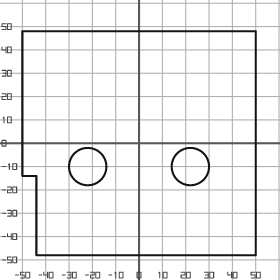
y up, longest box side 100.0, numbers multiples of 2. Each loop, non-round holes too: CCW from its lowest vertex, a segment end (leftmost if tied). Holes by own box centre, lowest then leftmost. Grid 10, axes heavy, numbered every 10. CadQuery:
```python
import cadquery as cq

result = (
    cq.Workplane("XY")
    .moveTo(-44.0, -48.0)
    .lineTo(50.0, -48.0)
    .lineTo(50.0, 48.0)
    .lineTo(-50.0, 48.0)
    .lineTo(-50.0, -14.0)
    .lineTo(-44.0, -14.0)
    .close()
    .moveTo(-22.0, -10.0)
    .circle(8.0)
    .moveTo(22.0, -10.0)
    .circle(8.0)
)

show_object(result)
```